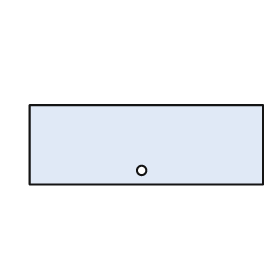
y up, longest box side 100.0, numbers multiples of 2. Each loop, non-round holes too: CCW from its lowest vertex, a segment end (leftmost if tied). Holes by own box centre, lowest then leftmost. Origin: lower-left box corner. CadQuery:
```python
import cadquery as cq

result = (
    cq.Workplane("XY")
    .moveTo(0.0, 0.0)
    .lineTo(100.0, 0.0)
    .lineTo(100.0, 34.0)
    .lineTo(0.0, 34.0)
    .close()
    .moveTo(48.0, 6.0)
    .circle(2.0)
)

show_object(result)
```